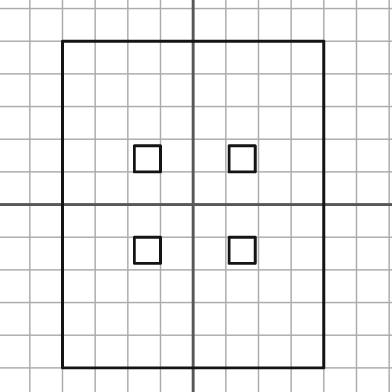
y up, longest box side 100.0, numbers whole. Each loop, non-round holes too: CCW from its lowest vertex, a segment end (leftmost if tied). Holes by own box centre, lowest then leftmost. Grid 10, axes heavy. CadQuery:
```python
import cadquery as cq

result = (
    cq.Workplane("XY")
    .moveTo(-40.0, -50.0)
    .lineTo(40.0, -50.0)
    .lineTo(40.0, 50.0)
    .lineTo(-40.0, 50.0)
    .close()
    .moveTo(-18.0, -18.0)
    .lineTo(-10.0, -18.0)
    .lineTo(-10.0, -10.0)
    .lineTo(-18.0, -10.0)
    .close()
    .moveTo(11.0, -18.0)
    .lineTo(19.0, -18.0)
    .lineTo(19.0, -10.0)
    .lineTo(11.0, -10.0)
    .close()
    .moveTo(-18.0, 10.0)
    .lineTo(-10.0, 10.0)
    .lineTo(-10.0, 18.0)
    .lineTo(-18.0, 18.0)
    .close()
    .moveTo(11.0, 10.0)
    .lineTo(19.0, 10.0)
    .lineTo(19.0, 18.0)
    .lineTo(11.0, 18.0)
    .close()
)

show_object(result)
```